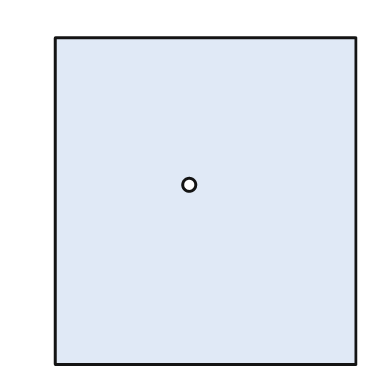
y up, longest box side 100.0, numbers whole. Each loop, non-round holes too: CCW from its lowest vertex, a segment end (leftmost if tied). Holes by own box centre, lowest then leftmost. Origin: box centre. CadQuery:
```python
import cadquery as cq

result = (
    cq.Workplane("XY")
    .moveTo(-46.0, -50.0)
    .lineTo(46.0, -50.0)
    .lineTo(46.0, 50.0)
    .lineTo(-46.0, 50.0)
    .close()
    .moveTo(-5.0, 5.0)
    .circle(2.0)
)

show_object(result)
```